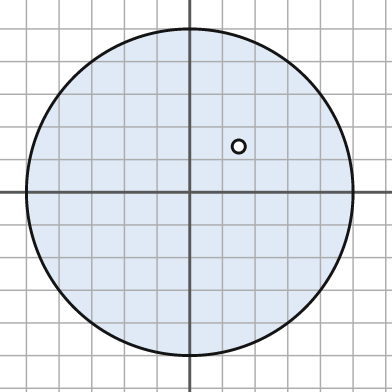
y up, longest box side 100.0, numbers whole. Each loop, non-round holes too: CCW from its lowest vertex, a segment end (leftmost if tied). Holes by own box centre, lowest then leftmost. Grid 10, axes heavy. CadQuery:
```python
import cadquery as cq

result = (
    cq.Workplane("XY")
    .moveTo(0.0, 0.0)
    .circle(50.0)
    .moveTo(15.0, 14.0)
    .circle(2.0)
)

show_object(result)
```